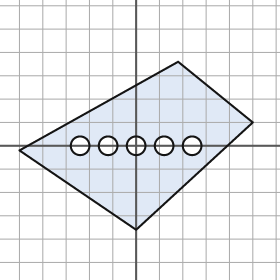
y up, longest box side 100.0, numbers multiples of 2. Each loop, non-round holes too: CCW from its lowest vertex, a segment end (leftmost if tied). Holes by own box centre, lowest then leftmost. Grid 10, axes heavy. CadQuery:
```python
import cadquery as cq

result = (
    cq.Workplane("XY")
    .moveTo(0.0, -36.0)
    .lineTo(50.0, 10.0)
    .lineTo(18.0, 36.0)
    .lineTo(-50.0, -2.0)
    .close()
    .moveTo(-24.0, 0.0)
    .circle(4.0)
    .moveTo(-12.0, 0.0)
    .circle(4.0)
    .moveTo(0.0, 0.0)
    .circle(4.0)
    .moveTo(12.0, 0.0)
    .circle(4.0)
    .moveTo(24.0, 0.0)
    .circle(4.0)
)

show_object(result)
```